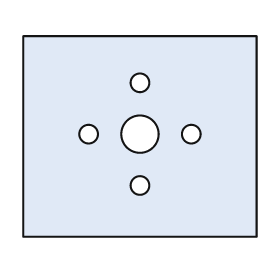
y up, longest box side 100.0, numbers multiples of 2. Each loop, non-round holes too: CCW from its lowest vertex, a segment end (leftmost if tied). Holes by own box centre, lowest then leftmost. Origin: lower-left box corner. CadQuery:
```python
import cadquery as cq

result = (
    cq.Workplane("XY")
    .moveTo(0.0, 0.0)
    .lineTo(100.0, 0.0)
    .lineTo(100.0, 86.0)
    .lineTo(0.0, 86.0)
    .close()
    .moveTo(50.0, 22.0)
    .circle(4.0)
    .moveTo(28.0, 44.0)
    .circle(4.0)
    .moveTo(50.0, 44.0)
    .circle(8.0)
    .moveTo(72.0, 44.0)
    .circle(4.0)
    .moveTo(50.0, 66.0)
    .circle(4.0)
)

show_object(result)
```